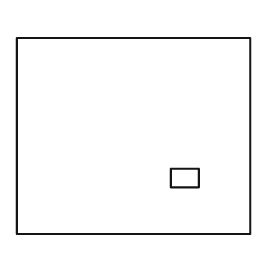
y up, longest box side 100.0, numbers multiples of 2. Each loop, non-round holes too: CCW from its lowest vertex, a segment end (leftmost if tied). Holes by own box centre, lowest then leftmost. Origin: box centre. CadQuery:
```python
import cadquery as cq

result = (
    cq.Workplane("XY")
    .moveTo(-50.0, -42.0)
    .lineTo(50.0, -42.0)
    .lineTo(50.0, 42.0)
    .lineTo(-50.0, 42.0)
    .close()
    .moveTo(16.0, -22.0)
    .lineTo(28.0, -22.0)
    .lineTo(28.0, -14.0)
    .lineTo(16.0, -14.0)
    .close()
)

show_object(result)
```